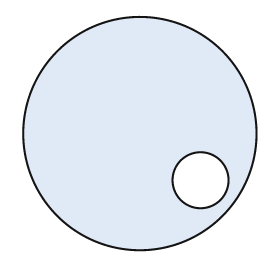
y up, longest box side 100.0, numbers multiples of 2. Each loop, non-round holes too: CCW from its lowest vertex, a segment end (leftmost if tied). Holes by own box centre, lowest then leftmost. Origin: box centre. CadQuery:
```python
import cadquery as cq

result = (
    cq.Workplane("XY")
    .moveTo(0.0, 0.0)
    .circle(50.0)
    .moveTo(26.0, -20.0)
    .circle(12.0)
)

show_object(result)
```